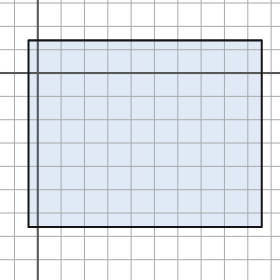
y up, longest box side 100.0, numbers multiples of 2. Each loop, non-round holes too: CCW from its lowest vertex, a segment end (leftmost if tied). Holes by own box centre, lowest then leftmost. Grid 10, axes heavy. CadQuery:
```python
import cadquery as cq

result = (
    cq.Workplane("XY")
    .moveTo(-4.0, -66.0)
    .lineTo(96.0, -66.0)
    .lineTo(96.0, 14.0)
    .lineTo(-4.0, 14.0)
    .close()
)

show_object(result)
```